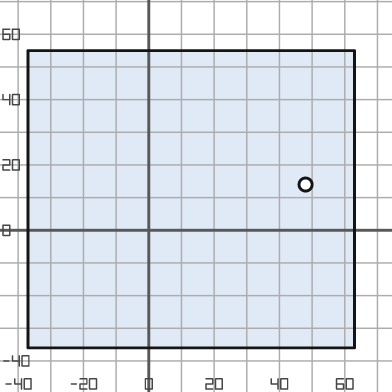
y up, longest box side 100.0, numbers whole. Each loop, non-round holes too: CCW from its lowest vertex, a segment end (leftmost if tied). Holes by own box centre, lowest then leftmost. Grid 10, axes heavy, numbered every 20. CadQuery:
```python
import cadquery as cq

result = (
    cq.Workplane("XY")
    .moveTo(-37.0, -36.0)
    .lineTo(63.0, -36.0)
    .lineTo(63.0, 55.0)
    .lineTo(-37.0, 55.0)
    .close()
    .moveTo(48.0, 14.0)
    .circle(2.0)
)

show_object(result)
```